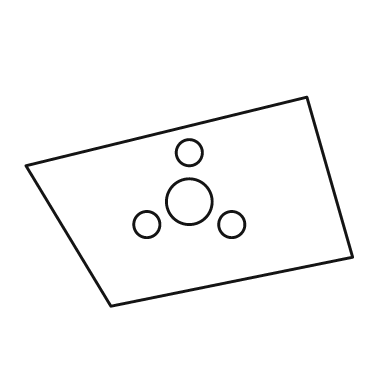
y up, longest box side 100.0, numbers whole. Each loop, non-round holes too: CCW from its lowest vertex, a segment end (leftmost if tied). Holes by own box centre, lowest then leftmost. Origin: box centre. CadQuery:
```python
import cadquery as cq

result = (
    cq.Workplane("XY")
    .moveTo(-24.0, -32.0)
    .lineTo(50.0, -17.0)
    .lineTo(36.0, 32.0)
    .lineTo(-50.0, 11.0)
    .close()
    .moveTo(-13.0, -7.0)
    .circle(4.0)
    .moveTo(13.0, -7.0)
    .circle(4.0)
    .moveTo(0.0, 0.0)
    .circle(7.0)
    .moveTo(0.0, 15.0)
    .circle(4.0)
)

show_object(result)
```